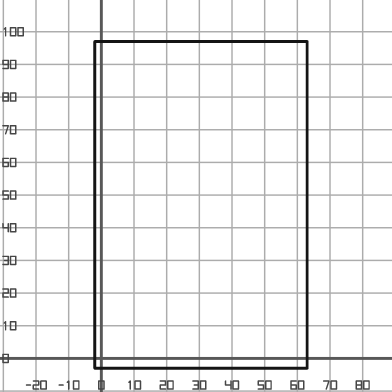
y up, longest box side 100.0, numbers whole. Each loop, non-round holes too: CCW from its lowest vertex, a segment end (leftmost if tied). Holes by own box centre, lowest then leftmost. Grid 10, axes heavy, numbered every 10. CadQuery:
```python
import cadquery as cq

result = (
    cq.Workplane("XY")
    .moveTo(-2.0, -3.0)
    .lineTo(63.0, -3.0)
    .lineTo(63.0, 97.0)
    .lineTo(-2.0, 97.0)
    .close()
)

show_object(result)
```